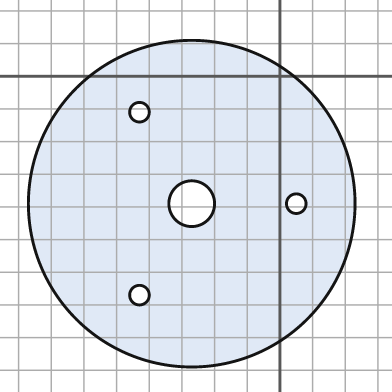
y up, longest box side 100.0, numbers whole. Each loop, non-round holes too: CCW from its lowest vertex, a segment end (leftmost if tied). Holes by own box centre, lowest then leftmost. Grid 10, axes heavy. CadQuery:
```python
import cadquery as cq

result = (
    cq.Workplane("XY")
    .moveTo(-27.0, -39.0)
    .circle(50.0)
    .moveTo(-43.0, -67.0)
    .circle(3.0)
    .moveTo(-27.0, -39.0)
    .circle(7.0)
    .moveTo(5.0, -39.0)
    .circle(3.0)
    .moveTo(-43.0, -11.0)
    .circle(3.0)
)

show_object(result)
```